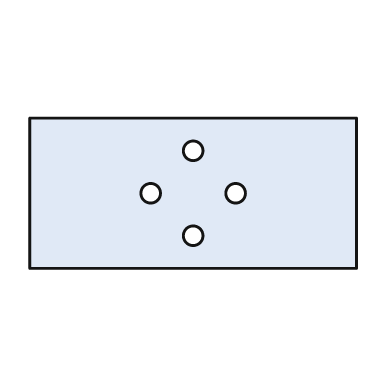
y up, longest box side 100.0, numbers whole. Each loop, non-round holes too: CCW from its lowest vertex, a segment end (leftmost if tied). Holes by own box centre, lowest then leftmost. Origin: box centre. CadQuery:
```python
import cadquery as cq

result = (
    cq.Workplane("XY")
    .moveTo(-50.0, -23.0)
    .lineTo(50.0, -23.0)
    .lineTo(50.0, 23.0)
    .lineTo(-50.0, 23.0)
    .close()
    .moveTo(0.0, -13.0)
    .circle(3.0)
    .moveTo(-13.0, 0.0)
    .circle(3.0)
    .moveTo(13.0, 0.0)
    .circle(3.0)
    .moveTo(0.0, 13.0)
    .circle(3.0)
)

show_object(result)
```